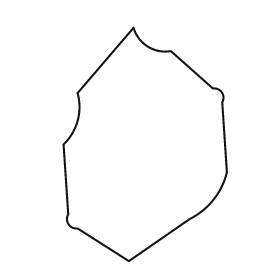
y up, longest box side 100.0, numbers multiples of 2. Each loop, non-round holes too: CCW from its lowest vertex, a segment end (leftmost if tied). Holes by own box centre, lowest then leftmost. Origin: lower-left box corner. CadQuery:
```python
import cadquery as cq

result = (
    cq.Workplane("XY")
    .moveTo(28.0, 0.0)
    .lineTo(54.0, 18.0)
    .threePointArc((64.0, 26.0), (70.0, 38.0))
    .lineTo(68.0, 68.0)
    .threePointArc((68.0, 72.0), (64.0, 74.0))
    .lineTo(46.0, 90.0)
    .threePointArc((36.0, 92.0), (30.0, 100.0))
    .lineTo(6.0, 72.0)
    .threePointArc((6.0, 60.0), (0.0, 50.0))
    .lineTo(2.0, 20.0)
    .threePointArc((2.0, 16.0), (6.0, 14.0))
    .close()
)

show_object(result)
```